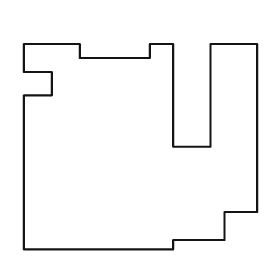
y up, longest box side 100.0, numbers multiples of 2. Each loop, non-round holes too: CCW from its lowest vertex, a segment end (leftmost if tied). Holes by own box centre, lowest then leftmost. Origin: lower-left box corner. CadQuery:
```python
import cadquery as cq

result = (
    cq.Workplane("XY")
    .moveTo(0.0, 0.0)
    .lineTo(64.0, 0.0)
    .lineTo(64.0, 4.0)
    .lineTo(86.0, 4.0)
    .lineTo(86.0, 16.0)
    .lineTo(100.0, 16.0)
    .lineTo(100.0, 88.0)
    .lineTo(80.0, 88.0)
    .lineTo(80.0, 44.0)
    .lineTo(64.0, 44.0)
    .lineTo(64.0, 88.0)
    .lineTo(54.0, 88.0)
    .lineTo(54.0, 82.0)
    .lineTo(24.0, 82.0)
    .lineTo(24.0, 88.0)
    .lineTo(0.0, 88.0)
    .lineTo(0.0, 76.0)
    .lineTo(12.0, 76.0)
    .lineTo(12.0, 66.0)
    .lineTo(0.0, 66.0)
    .close()
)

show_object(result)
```